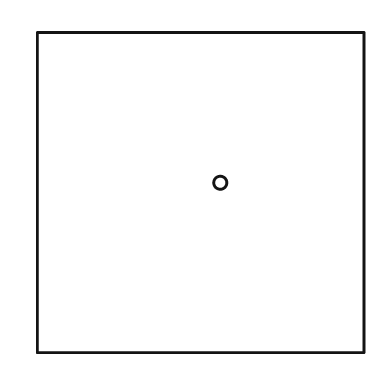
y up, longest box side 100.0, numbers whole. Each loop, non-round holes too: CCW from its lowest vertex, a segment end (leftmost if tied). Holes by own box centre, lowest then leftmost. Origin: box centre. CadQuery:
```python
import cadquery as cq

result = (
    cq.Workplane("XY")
    .moveTo(-50.0, -49.0)
    .lineTo(50.0, -49.0)
    .lineTo(50.0, 49.0)
    .lineTo(-50.0, 49.0)
    .close()
    .moveTo(6.0, 3.0)
    .circle(2.0)
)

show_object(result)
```